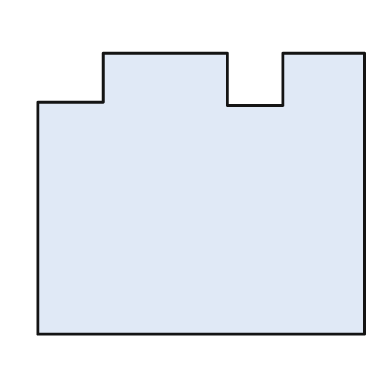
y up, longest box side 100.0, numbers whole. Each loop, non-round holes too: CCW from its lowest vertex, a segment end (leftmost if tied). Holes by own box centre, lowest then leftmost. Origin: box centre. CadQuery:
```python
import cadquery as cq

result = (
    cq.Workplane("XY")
    .moveTo(-50.0, -43.0)
    .lineTo(50.0, -43.0)
    .lineTo(50.0, 43.0)
    .lineTo(25.0, 43.0)
    .lineTo(25.0, 27.0)
    .lineTo(8.0, 27.0)
    .lineTo(8.0, 43.0)
    .lineTo(-30.0, 43.0)
    .lineTo(-30.0, 28.0)
    .lineTo(-50.0, 28.0)
    .close()
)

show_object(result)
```